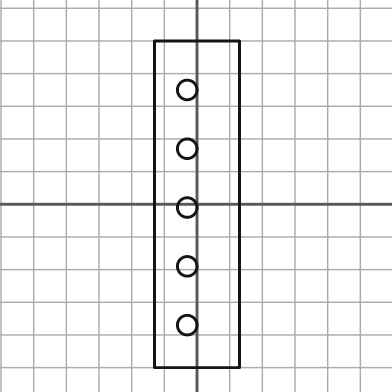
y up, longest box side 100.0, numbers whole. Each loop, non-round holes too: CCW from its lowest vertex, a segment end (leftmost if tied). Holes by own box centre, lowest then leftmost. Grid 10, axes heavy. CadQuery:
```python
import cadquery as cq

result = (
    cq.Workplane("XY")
    .moveTo(-13.0, -50.0)
    .lineTo(13.0, -50.0)
    .lineTo(13.0, 50.0)
    .lineTo(-13.0, 50.0)
    .close()
    .moveTo(-3.0, -37.0)
    .circle(3.0)
    .moveTo(-3.0, -19.0)
    .circle(3.0)
    .moveTo(-3.0, -1.0)
    .circle(3.0)
    .moveTo(-3.0, 17.0)
    .circle(3.0)
    .moveTo(-3.0, 35.0)
    .circle(3.0)
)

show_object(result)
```